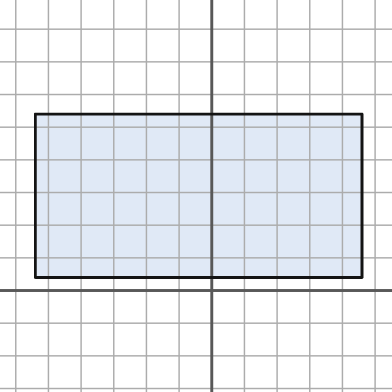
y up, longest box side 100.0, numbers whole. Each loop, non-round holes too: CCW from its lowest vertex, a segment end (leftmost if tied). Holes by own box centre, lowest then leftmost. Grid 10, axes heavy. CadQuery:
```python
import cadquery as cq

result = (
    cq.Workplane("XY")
    .moveTo(-54.0, 4.0)
    .lineTo(46.0, 4.0)
    .lineTo(46.0, 54.0)
    .lineTo(-54.0, 54.0)
    .close()
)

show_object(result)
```